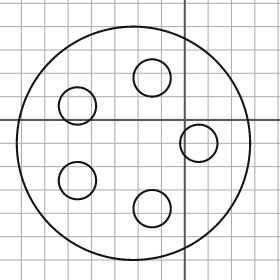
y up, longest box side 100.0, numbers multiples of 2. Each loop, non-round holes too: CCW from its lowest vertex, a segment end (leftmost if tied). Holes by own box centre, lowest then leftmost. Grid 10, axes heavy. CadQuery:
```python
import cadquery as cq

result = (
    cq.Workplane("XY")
    .moveTo(-22.0, -10.0)
    .circle(50.0)
    .moveTo(-14.0, -38.0)
    .circle(8.0)
    .moveTo(-46.0, -26.0)
    .circle(8.0)
    .moveTo(6.0, -10.0)
    .circle(8.0)
    .moveTo(-46.0, 6.0)
    .circle(8.0)
    .moveTo(-14.0, 18.0)
    .circle(8.0)
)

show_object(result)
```